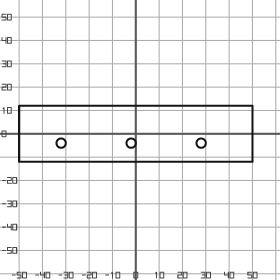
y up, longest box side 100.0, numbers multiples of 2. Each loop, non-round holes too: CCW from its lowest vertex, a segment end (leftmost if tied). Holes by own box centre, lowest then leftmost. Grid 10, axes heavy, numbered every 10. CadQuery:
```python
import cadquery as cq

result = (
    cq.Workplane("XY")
    .moveTo(-50.0, -12.0)
    .lineTo(50.0, -12.0)
    .lineTo(50.0, 12.0)
    .lineTo(-50.0, 12.0)
    .close()
    .moveTo(-32.0, -4.0)
    .circle(2.0)
    .moveTo(-2.0, -4.0)
    .circle(2.0)
    .moveTo(28.0, -4.0)
    .circle(2.0)
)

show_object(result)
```